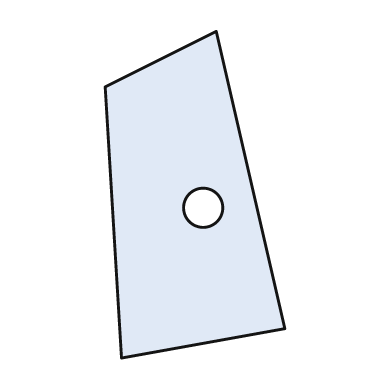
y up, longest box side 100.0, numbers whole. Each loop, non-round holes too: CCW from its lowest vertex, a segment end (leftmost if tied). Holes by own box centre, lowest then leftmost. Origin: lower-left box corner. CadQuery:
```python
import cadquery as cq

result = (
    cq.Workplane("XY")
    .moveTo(5.0, 0.0)
    .lineTo(55.0, 9.0)
    .lineTo(34.0, 100.0)
    .lineTo(0.0, 83.0)
    .close()
    .moveTo(30.0, 46.0)
    .circle(6.0)
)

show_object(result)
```